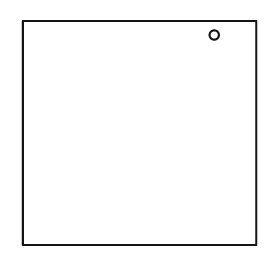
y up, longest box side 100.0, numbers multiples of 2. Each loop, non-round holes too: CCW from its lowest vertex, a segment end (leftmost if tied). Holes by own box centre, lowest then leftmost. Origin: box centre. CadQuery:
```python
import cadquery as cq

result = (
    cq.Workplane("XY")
    .moveTo(-50.0, -48.0)
    .lineTo(50.0, -48.0)
    .lineTo(50.0, 48.0)
    .lineTo(-50.0, 48.0)
    .close()
    .moveTo(32.0, 42.0)
    .circle(2.0)
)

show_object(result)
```